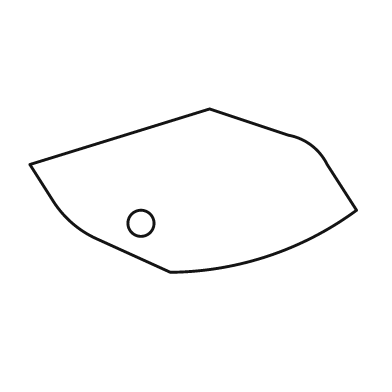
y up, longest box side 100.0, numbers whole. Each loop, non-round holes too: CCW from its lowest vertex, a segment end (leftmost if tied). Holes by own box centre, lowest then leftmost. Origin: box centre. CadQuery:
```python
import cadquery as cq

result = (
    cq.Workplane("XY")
    .moveTo(-7.0, -25.0)
    .threePointArc((23.0, -20.0), (50.0, -6.0))
    .lineTo(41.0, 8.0)
    .threePointArc((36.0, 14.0), (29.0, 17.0))
    .lineTo(5.0, 25.0)
    .lineTo(-50.0, 8.0)
    .lineTo(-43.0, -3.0)
    .threePointArc((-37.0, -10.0), (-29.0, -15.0))
    .close()
    .moveTo(-16.0, -10.0)
    .circle(4.0)
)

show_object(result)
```